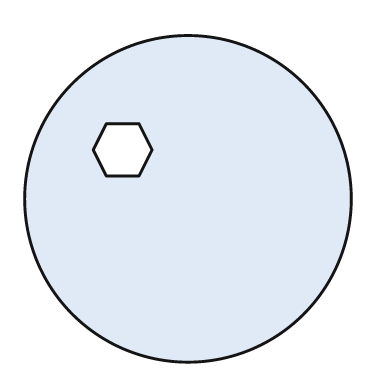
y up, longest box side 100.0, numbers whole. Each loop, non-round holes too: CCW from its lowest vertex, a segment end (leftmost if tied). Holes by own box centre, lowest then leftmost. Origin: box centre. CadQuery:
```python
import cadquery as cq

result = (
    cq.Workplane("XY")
    .moveTo(0.0, 0.0)
    .circle(50.0)
    .moveTo(-25.0, 7.0)
    .lineTo(-15.0, 7.0)
    .lineTo(-11.0, 15.0)
    .lineTo(-15.0, 23.0)
    .lineTo(-25.0, 23.0)
    .lineTo(-29.0, 15.0)
    .close()
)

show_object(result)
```